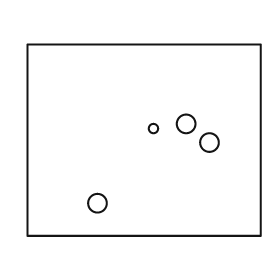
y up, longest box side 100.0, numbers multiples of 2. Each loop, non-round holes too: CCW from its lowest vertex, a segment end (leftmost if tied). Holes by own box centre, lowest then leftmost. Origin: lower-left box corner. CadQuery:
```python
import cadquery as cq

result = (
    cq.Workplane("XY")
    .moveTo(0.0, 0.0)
    .lineTo(100.0, 0.0)
    .lineTo(100.0, 82.0)
    .lineTo(0.0, 82.0)
    .close()
    .moveTo(30.0, 14.0)
    .circle(4.0)
    .moveTo(78.0, 40.0)
    .circle(4.0)
    .moveTo(54.0, 46.0)
    .circle(2.0)
    .moveTo(68.0, 48.0)
    .circle(4.0)
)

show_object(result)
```